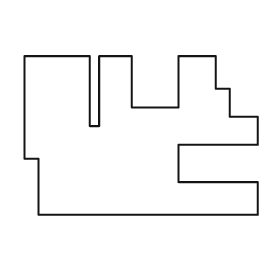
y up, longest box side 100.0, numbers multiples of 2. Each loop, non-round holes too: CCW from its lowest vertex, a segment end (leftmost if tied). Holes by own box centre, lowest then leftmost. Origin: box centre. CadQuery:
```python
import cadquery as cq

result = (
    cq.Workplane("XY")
    .moveTo(-44.0, -34.0)
    .lineTo(50.0, -34.0)
    .lineTo(50.0, -20.0)
    .lineTo(16.0, -20.0)
    .lineTo(16.0, -4.0)
    .lineTo(50.0, -4.0)
    .lineTo(50.0, 8.0)
    .lineTo(38.0, 8.0)
    .lineTo(38.0, 20.0)
    .lineTo(32.0, 20.0)
    .lineTo(32.0, 34.0)
    .lineTo(16.0, 34.0)
    .lineTo(16.0, 12.0)
    .lineTo(-4.0, 12.0)
    .lineTo(-4.0, 34.0)
    .lineTo(-18.0, 34.0)
    .lineTo(-18.0, 4.0)
    .lineTo(-22.0, 4.0)
    .lineTo(-22.0, 34.0)
    .lineTo(-50.0, 34.0)
    .lineTo(-50.0, -10.0)
    .lineTo(-44.0, -10.0)
    .close()
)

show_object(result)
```